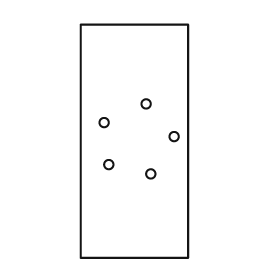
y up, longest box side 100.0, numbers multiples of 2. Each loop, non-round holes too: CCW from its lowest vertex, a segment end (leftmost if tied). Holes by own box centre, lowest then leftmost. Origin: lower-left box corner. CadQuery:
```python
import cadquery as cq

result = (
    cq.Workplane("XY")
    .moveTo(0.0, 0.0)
    .lineTo(46.0, 0.0)
    .lineTo(46.0, 100.0)
    .lineTo(0.0, 100.0)
    .close()
    .moveTo(30.0, 36.0)
    .circle(2.0)
    .moveTo(12.0, 40.0)
    .circle(2.0)
    .moveTo(40.0, 52.0)
    .circle(2.0)
    .moveTo(10.0, 58.0)
    .circle(2.0)
    .moveTo(28.0, 66.0)
    .circle(2.0)
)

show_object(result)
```